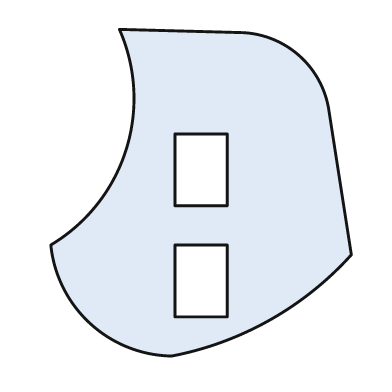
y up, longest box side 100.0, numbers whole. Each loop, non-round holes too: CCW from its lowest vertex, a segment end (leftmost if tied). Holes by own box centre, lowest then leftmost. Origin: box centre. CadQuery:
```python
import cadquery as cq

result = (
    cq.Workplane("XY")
    .moveTo(-9.0, -50.0)
    .threePointArc((21.0, -39.0), (46.0, -19.0))
    .lineTo(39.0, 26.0)
    .threePointArc((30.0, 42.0), (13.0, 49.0))
    .lineTo(-25.0, 50.0)
    .threePointArc((-23.0, 13.0), (-46.0, -16.0))
    .threePointArc((-34.0, -40.0), (-9.0, -50.0))
    .close()
    .moveTo(-8.0, -38.0)
    .lineTo(8.0, -38.0)
    .lineTo(8.0, -16.0)
    .lineTo(-8.0, -16.0)
    .close()
    .moveTo(-8.0, -4.0)
    .lineTo(8.0, -4.0)
    .lineTo(8.0, 18.0)
    .lineTo(-8.0, 18.0)
    .close()
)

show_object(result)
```